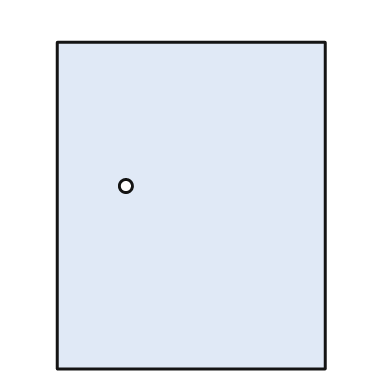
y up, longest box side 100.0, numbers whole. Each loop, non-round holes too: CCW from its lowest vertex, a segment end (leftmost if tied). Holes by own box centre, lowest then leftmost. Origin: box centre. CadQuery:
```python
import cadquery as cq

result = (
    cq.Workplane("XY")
    .moveTo(-41.0, -50.0)
    .lineTo(41.0, -50.0)
    .lineTo(41.0, 50.0)
    .lineTo(-41.0, 50.0)
    .close()
    .moveTo(-20.0, 6.0)
    .circle(2.0)
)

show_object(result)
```